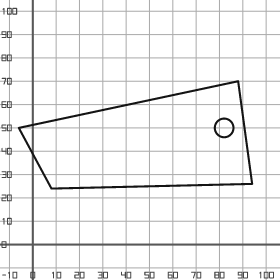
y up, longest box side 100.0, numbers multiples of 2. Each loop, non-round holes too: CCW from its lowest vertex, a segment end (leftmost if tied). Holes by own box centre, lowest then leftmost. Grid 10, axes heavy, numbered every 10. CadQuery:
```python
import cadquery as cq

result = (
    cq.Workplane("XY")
    .moveTo(8.0, 24.0)
    .lineTo(94.0, 26.0)
    .lineTo(88.0, 70.0)
    .lineTo(-6.0, 50.0)
    .close()
    .moveTo(82.0, 50.0)
    .circle(4.0)
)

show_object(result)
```